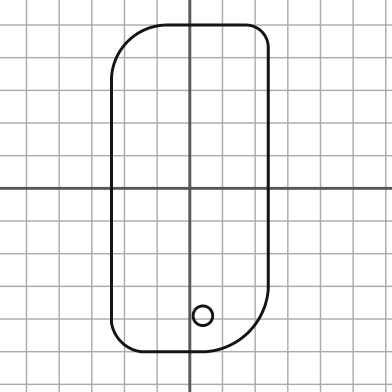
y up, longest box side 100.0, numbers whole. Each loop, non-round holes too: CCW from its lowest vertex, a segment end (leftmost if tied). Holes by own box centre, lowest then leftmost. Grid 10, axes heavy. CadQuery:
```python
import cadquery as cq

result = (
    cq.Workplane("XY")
    .moveTo(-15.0, -50.0)
    .lineTo(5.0, -50.0)
    .threePointArc((18.0, -44.0), (24.0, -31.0))
    .lineTo(24.0, 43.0)
    .threePointArc((22.0, 48.0), (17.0, 50.0))
    .lineTo(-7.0, 50.0)
    .threePointArc((-19.0, 45.0), (-24.0, 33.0))
    .lineTo(-24.0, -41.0)
    .threePointArc((-21.0, -47.0), (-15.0, -50.0))
    .close()
    .moveTo(4.0, -39.0)
    .circle(3.0)
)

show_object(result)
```